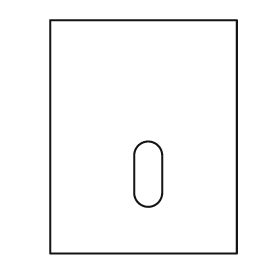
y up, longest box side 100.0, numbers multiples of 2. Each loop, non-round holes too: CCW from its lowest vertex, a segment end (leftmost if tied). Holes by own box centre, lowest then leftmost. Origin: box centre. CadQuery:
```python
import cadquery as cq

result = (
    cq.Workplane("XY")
    .moveTo(-40.0, -50.0)
    .lineTo(40.0, -50.0)
    .lineTo(40.0, 50.0)
    .lineTo(-40.0, 50.0)
    .close()
    .moveTo(-4.0, -24.0)
    .threePointArc((2.0, -30.0), (8.0, -24.0))
    .lineTo(8.0, -8.0)
    .threePointArc((2.0, -2.0), (-4.0, -8.0))
    .close()
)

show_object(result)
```